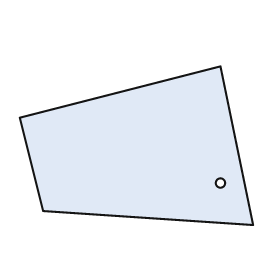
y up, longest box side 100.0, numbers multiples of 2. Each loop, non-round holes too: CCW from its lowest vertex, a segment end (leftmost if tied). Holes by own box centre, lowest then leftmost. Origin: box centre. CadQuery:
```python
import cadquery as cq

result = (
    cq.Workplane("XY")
    .moveTo(50.0, -34.0)
    .lineTo(36.0, 34.0)
    .lineTo(-50.0, 12.0)
    .lineTo(-40.0, -28.0)
    .close()
    .moveTo(36.0, -16.0)
    .circle(2.0)
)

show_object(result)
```